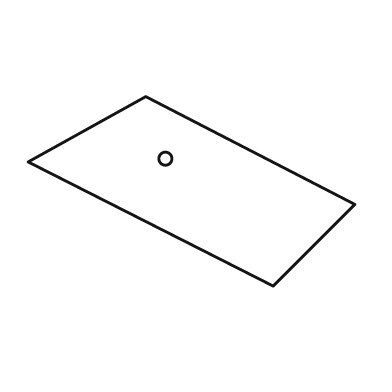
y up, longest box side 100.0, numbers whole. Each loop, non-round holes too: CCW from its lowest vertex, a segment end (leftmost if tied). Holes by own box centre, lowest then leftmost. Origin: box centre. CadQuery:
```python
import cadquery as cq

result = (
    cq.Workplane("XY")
    .moveTo(25.0, -29.0)
    .lineTo(50.0, -4.0)
    .lineTo(-14.0, 29.0)
    .lineTo(-50.0, 9.0)
    .close()
    .moveTo(-8.0, 10.0)
    .circle(2.0)
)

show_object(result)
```